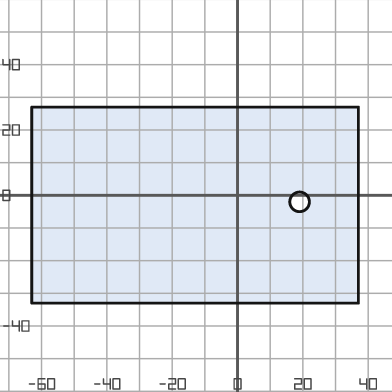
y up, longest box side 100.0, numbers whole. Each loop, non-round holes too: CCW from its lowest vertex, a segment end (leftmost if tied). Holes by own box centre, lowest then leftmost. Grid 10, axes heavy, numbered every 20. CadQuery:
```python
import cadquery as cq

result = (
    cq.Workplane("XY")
    .moveTo(-63.0, -33.0)
    .lineTo(37.0, -33.0)
    .lineTo(37.0, 27.0)
    .lineTo(-63.0, 27.0)
    .close()
    .moveTo(19.0, -2.0)
    .circle(3.0)
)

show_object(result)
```